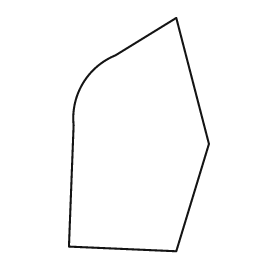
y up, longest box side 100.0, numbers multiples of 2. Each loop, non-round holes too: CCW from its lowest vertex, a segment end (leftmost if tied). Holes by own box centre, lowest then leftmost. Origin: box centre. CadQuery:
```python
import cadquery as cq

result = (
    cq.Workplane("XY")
    .moveTo(16.0, -50.0)
    .lineTo(30.0, -4.0)
    .lineTo(16.0, 50.0)
    .lineTo(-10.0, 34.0)
    .threePointArc((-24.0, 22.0), (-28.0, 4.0))
    .lineTo(-30.0, -48.0)
    .close()
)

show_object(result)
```